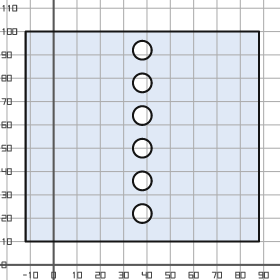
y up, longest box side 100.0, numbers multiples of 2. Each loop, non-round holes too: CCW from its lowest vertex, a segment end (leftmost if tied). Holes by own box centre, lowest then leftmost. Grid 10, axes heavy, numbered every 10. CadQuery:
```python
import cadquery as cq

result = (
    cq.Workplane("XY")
    .moveTo(-12.0, 10.0)
    .lineTo(88.0, 10.0)
    .lineTo(88.0, 100.0)
    .lineTo(-12.0, 100.0)
    .close()
    .moveTo(38.0, 22.0)
    .circle(4.0)
    .moveTo(38.0, 36.0)
    .circle(4.0)
    .moveTo(38.0, 50.0)
    .circle(4.0)
    .moveTo(38.0, 64.0)
    .circle(4.0)
    .moveTo(38.0, 78.0)
    .circle(4.0)
    .moveTo(38.0, 92.0)
    .circle(4.0)
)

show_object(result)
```